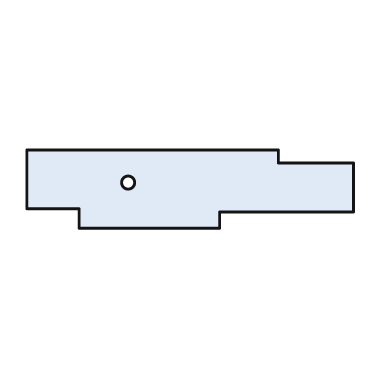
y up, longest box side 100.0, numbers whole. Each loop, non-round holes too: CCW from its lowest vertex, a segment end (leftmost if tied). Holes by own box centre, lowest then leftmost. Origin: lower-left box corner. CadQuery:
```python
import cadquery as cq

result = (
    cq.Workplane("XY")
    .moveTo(16.0, 0.0)
    .lineTo(59.0, 0.0)
    .lineTo(59.0, 5.0)
    .lineTo(100.0, 5.0)
    .lineTo(100.0, 20.0)
    .lineTo(77.0, 20.0)
    .lineTo(77.0, 24.0)
    .lineTo(0.0, 24.0)
    .lineTo(0.0, 6.0)
    .lineTo(16.0, 6.0)
    .close()
    .moveTo(31.0, 14.0)
    .circle(2.0)
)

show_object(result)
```